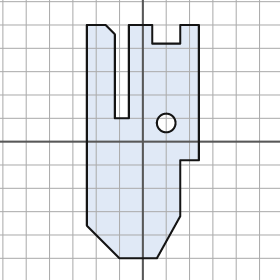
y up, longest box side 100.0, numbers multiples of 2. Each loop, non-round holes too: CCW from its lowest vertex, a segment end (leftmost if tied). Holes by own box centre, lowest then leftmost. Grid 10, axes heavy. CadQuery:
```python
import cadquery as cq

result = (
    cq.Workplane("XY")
    .moveTo(-10.0, -50.0)
    .lineTo(6.0, -50.0)
    .lineTo(16.0, -32.0)
    .lineTo(16.0, -8.0)
    .lineTo(24.0, -8.0)
    .lineTo(24.0, 50.0)
    .lineTo(16.0, 50.0)
    .lineTo(16.0, 42.0)
    .lineTo(4.0, 42.0)
    .lineTo(4.0, 50.0)
    .lineTo(-6.0, 50.0)
    .lineTo(-6.0, 10.0)
    .lineTo(-12.0, 10.0)
    .lineTo(-12.0, 46.0)
    .lineTo(-16.0, 50.0)
    .lineTo(-24.0, 50.0)
    .lineTo(-24.0, -36.0)
    .close()
    .moveTo(10.0, 8.0)
    .circle(4.0)
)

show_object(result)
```